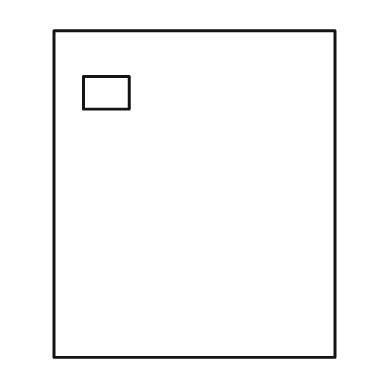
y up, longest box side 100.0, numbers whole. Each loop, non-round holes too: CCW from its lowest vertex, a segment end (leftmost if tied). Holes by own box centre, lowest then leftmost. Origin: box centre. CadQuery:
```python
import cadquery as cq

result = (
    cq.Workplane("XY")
    .moveTo(-43.0, -50.0)
    .lineTo(43.0, -50.0)
    .lineTo(43.0, 50.0)
    .lineTo(-43.0, 50.0)
    .close()
    .moveTo(-34.0, 26.0)
    .lineTo(-20.0, 26.0)
    .lineTo(-20.0, 36.0)
    .lineTo(-34.0, 36.0)
    .close()
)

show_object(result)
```